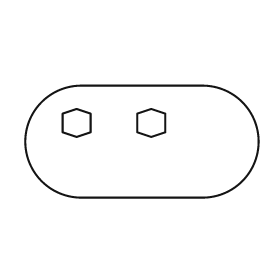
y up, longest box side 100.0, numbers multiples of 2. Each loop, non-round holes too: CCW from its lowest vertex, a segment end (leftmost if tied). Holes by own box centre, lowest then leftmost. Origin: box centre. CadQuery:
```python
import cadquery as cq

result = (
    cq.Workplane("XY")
    .moveTo(-26.0, -24.0)
    .lineTo(26.0, -24.0)
    .threePointArc((50.0, 0.0), (26.0, 24.0))
    .lineTo(-26.0, 24.0)
    .threePointArc((-50.0, 0.0), (-26.0, -24.0))
    .close()
    .moveTo(-28.0, 2.0)
    .lineTo(-22.0, 4.0)
    .lineTo(-22.0, 12.0)
    .lineTo(-28.0, 14.0)
    .lineTo(-34.0, 12.0)
    .lineTo(-34.0, 4.0)
    .close()
    .moveTo(4.0, 2.0)
    .lineTo(10.0, 4.0)
    .lineTo(10.0, 12.0)
    .lineTo(4.0, 14.0)
    .lineTo(-2.0, 12.0)
    .lineTo(-2.0, 4.0)
    .close()
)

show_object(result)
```